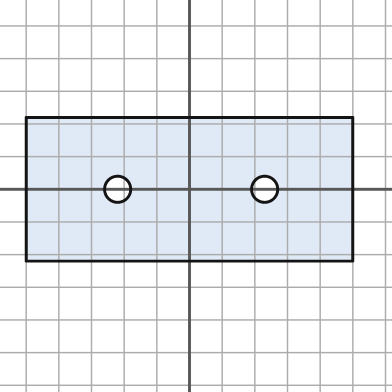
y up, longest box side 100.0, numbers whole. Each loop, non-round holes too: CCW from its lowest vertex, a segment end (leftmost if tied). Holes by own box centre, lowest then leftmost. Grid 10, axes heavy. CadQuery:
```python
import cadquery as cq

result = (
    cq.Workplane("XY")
    .moveTo(-50.0, -22.0)
    .lineTo(50.0, -22.0)
    .lineTo(50.0, 22.0)
    .lineTo(-50.0, 22.0)
    .close()
    .moveTo(-22.0, 0.0)
    .circle(4.0)
    .moveTo(23.0, 0.0)
    .circle(4.0)
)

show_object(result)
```